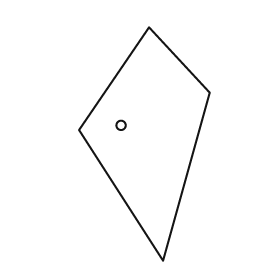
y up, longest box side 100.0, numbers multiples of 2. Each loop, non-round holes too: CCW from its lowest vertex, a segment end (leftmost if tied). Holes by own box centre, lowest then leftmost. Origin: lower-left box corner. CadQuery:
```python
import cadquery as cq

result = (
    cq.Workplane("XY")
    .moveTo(36.0, 0.0)
    .lineTo(56.0, 72.0)
    .lineTo(30.0, 100.0)
    .lineTo(0.0, 56.0)
    .close()
    .moveTo(18.0, 58.0)
    .circle(2.0)
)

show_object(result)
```